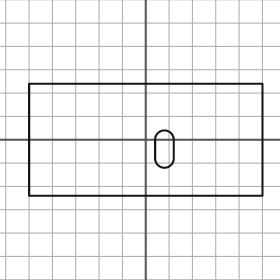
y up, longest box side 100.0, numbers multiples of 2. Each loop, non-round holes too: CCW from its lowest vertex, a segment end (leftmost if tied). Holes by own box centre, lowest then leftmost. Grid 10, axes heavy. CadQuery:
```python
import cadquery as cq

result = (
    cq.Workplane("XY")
    .moveTo(-50.0, -24.0)
    .lineTo(50.0, -24.0)
    .lineTo(50.0, 24.0)
    .lineTo(-50.0, 24.0)
    .close()
    .moveTo(4.0, -8.0)
    .threePointArc((8.0, -12.0), (12.0, -8.0))
    .lineTo(12.0, 0.0)
    .threePointArc((8.0, 4.0), (4.0, 0.0))
    .close()
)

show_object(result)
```